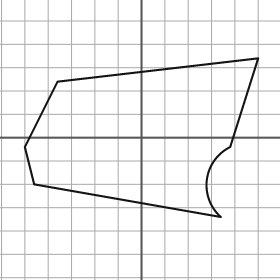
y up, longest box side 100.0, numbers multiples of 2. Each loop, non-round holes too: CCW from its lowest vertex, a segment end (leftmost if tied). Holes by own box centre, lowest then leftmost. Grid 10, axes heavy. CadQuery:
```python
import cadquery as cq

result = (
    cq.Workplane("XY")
    .moveTo(34.0, -34.0)
    .threePointArc((28.0, -18.0), (38.0, -4.0))
    .lineTo(50.0, 34.0)
    .lineTo(-36.0, 24.0)
    .lineTo(-50.0, -4.0)
    .lineTo(-46.0, -20.0)
    .close()
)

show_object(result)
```